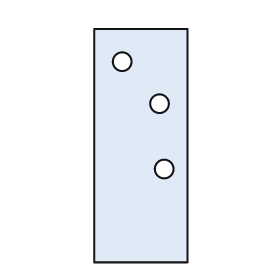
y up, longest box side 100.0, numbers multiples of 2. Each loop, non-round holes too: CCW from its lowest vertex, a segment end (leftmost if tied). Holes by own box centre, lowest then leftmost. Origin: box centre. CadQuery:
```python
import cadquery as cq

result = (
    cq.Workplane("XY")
    .moveTo(-20.0, -50.0)
    .lineTo(20.0, -50.0)
    .lineTo(20.0, 50.0)
    .lineTo(-20.0, 50.0)
    .close()
    .moveTo(10.0, -10.0)
    .circle(4.0)
    .moveTo(8.0, 18.0)
    .circle(4.0)
    .moveTo(-8.0, 36.0)
    .circle(4.0)
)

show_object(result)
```